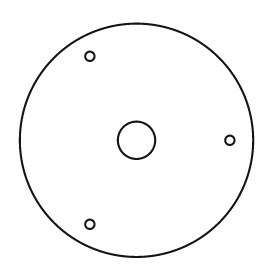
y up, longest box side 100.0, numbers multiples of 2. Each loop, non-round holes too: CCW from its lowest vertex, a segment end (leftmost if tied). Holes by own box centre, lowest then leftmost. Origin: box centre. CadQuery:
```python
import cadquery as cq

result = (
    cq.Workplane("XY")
    .moveTo(0.0, 0.0)
    .circle(50.0)
    .moveTo(-20.0, -36.0)
    .circle(2.0)
    .moveTo(0.0, 0.0)
    .circle(8.0)
    .moveTo(40.0, 0.0)
    .circle(2.0)
    .moveTo(-20.0, 36.0)
    .circle(2.0)
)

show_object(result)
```